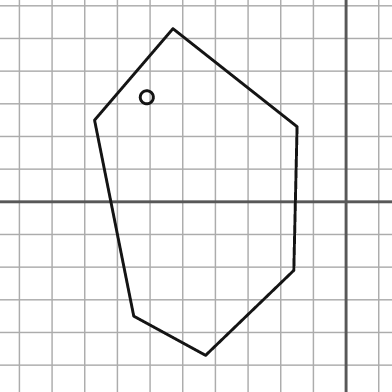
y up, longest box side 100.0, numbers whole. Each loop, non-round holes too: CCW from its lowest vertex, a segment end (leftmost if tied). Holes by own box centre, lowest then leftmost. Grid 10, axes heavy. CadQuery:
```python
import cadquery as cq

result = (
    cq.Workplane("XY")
    .moveTo(-43.0, -47.0)
    .lineTo(-16.0, -21.0)
    .lineTo(-15.0, 23.0)
    .lineTo(-53.0, 53.0)
    .lineTo(-77.0, 25.0)
    .lineTo(-65.0, -35.0)
    .close()
    .moveTo(-61.0, 32.0)
    .circle(2.0)
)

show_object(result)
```